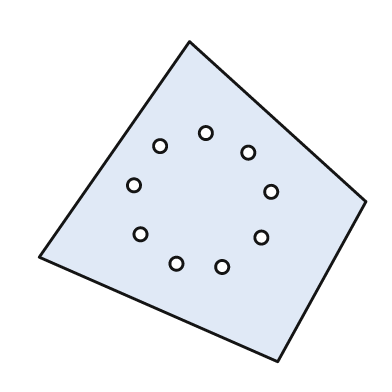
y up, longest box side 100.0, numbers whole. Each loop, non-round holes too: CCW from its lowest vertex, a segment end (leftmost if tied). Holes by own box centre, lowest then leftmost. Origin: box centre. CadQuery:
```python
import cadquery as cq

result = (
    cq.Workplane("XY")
    .moveTo(23.0, -49.0)
    .lineTo(50.0, 0.0)
    .lineTo(-4.0, 49.0)
    .lineTo(-50.0, -17.0)
    .close()
    .moveTo(6.0, -20.0)
    .circle(2.0)
    .moveTo(-8.0, -19.0)
    .circle(2.0)
    .moveTo(18.0, -11.0)
    .circle(2.0)
    .moveTo(-19.0, -10.0)
    .circle(2.0)
    .moveTo(21.0, 3.0)
    .circle(2.0)
    .moveTo(-21.0, 5.0)
    .circle(2.0)
    .moveTo(14.0, 15.0)
    .circle(2.0)
    .moveTo(-13.0, 17.0)
    .circle(2.0)
    .moveTo(1.0, 21.0)
    .circle(2.0)
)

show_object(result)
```